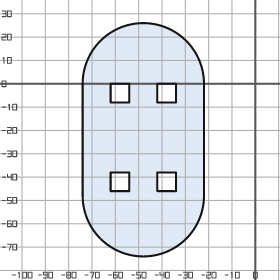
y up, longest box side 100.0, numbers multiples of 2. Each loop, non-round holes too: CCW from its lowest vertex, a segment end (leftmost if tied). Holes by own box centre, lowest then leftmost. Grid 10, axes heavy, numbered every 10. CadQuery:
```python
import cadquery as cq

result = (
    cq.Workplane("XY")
    .moveTo(-74.0, -48.0)
    .threePointArc((-48.0, -74.0), (-22.0, -48.0))
    .lineTo(-22.0, 0.0)
    .threePointArc((-48.0, 26.0), (-74.0, 0.0))
    .close()
    .moveTo(-62.0, -46.0)
    .lineTo(-54.0, -46.0)
    .lineTo(-54.0, -38.0)
    .lineTo(-62.0, -38.0)
    .close()
    .moveTo(-42.0, -46.0)
    .lineTo(-34.0, -46.0)
    .lineTo(-34.0, -38.0)
    .lineTo(-42.0, -38.0)
    .close()
    .moveTo(-62.0, -8.0)
    .lineTo(-54.0, -8.0)
    .lineTo(-54.0, 0.0)
    .lineTo(-62.0, 0.0)
    .close()
    .moveTo(-42.0, -8.0)
    .lineTo(-34.0, -8.0)
    .lineTo(-34.0, 0.0)
    .lineTo(-42.0, 0.0)
    .close()
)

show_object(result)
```